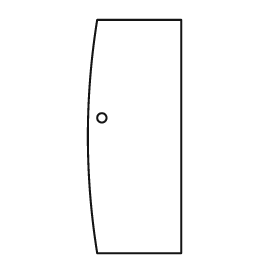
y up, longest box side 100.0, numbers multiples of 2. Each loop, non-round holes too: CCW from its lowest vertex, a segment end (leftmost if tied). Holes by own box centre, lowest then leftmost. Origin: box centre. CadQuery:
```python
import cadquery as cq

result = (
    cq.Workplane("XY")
    .moveTo(-16.0, -50.0)
    .lineTo(20.0, -50.0)
    .lineTo(20.0, 50.0)
    .lineTo(-16.0, 50.0)
    .threePointArc((-20.0, 0.0), (-16.0, -50.0))
    .close()
    .moveTo(-14.0, 8.0)
    .circle(2.0)
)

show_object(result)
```